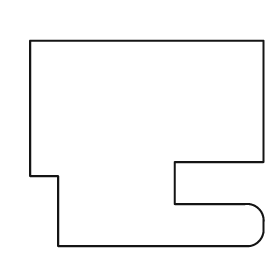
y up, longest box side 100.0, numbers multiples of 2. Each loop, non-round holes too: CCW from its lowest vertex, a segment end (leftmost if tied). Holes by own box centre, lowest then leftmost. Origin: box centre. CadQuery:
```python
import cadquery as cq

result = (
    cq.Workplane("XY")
    .moveTo(-38.0, -44.0)
    .lineTo(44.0, -44.0)
    .threePointArc((48.0, -42.0), (50.0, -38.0))
    .lineTo(50.0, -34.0)
    .threePointArc((48.0, -28.0), (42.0, -26.0))
    .lineTo(12.0, -26.0)
    .lineTo(12.0, -8.0)
    .lineTo(50.0, -8.0)
    .lineTo(50.0, 44.0)
    .lineTo(-50.0, 44.0)
    .lineTo(-50.0, -14.0)
    .lineTo(-38.0, -14.0)
    .close()
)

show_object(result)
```